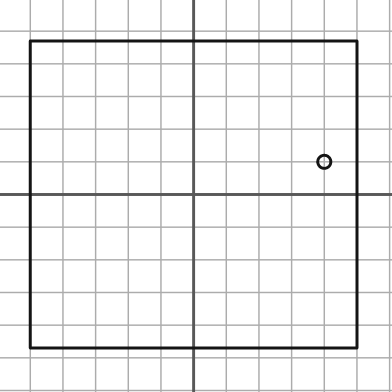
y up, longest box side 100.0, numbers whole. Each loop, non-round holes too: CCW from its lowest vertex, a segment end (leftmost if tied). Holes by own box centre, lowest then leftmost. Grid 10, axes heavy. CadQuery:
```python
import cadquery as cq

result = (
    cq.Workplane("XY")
    .moveTo(-50.0, -47.0)
    .lineTo(50.0, -47.0)
    .lineTo(50.0, 47.0)
    .lineTo(-50.0, 47.0)
    .close()
    .moveTo(40.0, 10.0)
    .circle(2.0)
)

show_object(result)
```